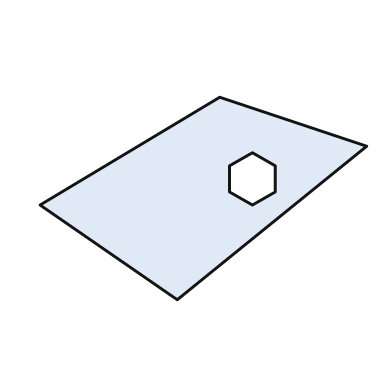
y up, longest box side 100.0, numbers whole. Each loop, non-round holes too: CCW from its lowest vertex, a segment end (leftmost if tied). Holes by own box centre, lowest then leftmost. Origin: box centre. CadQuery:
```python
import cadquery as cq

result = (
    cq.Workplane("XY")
    .moveTo(-8.0, -31.0)
    .lineTo(50.0, 16.0)
    .lineTo(5.0, 31.0)
    .lineTo(-50.0, -2.0)
    .close()
    .moveTo(15.0, -2.0)
    .lineTo(22.0, 2.0)
    .lineTo(22.0, 10.0)
    .lineTo(15.0, 14.0)
    .lineTo(8.0, 10.0)
    .lineTo(8.0, 2.0)
    .close()
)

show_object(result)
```